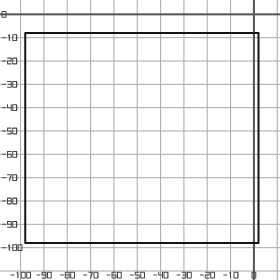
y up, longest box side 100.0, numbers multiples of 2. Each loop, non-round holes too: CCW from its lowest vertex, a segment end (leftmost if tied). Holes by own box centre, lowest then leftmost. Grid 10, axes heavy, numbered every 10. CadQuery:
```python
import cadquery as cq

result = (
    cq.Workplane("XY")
    .moveTo(-98.0, -98.0)
    .lineTo(2.0, -98.0)
    .lineTo(2.0, -8.0)
    .lineTo(-98.0, -8.0)
    .close()
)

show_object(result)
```